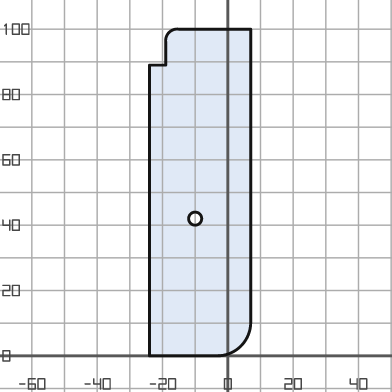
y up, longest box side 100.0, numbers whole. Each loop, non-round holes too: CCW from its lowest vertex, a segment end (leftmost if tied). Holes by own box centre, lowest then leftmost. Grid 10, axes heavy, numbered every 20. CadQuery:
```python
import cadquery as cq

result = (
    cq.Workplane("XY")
    .moveTo(-24.0, 0.0)
    .lineTo(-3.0, 0.0)
    .threePointArc((4.0, 3.0), (7.0, 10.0))
    .lineTo(7.0, 100.0)
    .lineTo(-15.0, 100.0)
    .threePointArc((-18.0, 99.0), (-19.0, 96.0))
    .lineTo(-19.0, 89.0)
    .lineTo(-24.0, 89.0)
    .close()
    .moveTo(-10.0, 42.0)
    .circle(2.0)
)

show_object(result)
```